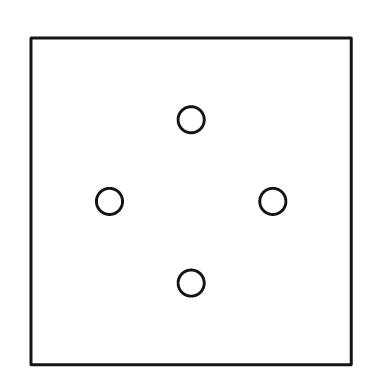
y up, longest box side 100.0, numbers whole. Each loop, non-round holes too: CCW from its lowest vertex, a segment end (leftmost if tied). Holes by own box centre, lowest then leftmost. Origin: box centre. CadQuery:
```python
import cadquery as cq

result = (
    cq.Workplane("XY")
    .moveTo(-49.0, -50.0)
    .lineTo(49.0, -50.0)
    .lineTo(49.0, 50.0)
    .lineTo(-49.0, 50.0)
    .close()
    .moveTo(0.0, -25.0)
    .circle(4.0)
    .moveTo(-25.0, 0.0)
    .circle(4.0)
    .moveTo(25.0, 0.0)
    .circle(4.0)
    .moveTo(0.0, 25.0)
    .circle(4.0)
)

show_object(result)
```